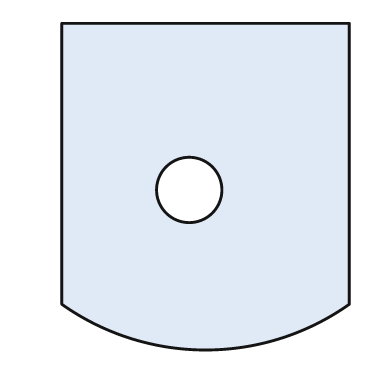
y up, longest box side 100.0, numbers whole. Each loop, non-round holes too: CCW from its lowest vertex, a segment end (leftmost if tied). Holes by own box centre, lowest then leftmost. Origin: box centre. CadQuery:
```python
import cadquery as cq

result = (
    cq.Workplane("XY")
    .moveTo(-44.0, -36.0)
    .threePointArc((0.0, -50.0), (44.0, -36.0))
    .lineTo(44.0, 50.0)
    .lineTo(-44.0, 50.0)
    .close()
    .moveTo(-5.0, -1.0)
    .circle(10.0)
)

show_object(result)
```